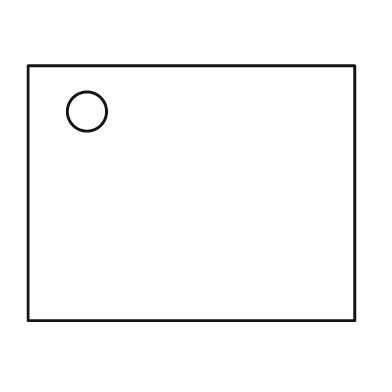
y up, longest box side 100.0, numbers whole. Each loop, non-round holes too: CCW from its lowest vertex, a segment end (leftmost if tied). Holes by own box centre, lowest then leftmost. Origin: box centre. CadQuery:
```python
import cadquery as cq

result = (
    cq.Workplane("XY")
    .moveTo(-50.0, -39.0)
    .lineTo(50.0, -39.0)
    .lineTo(50.0, 39.0)
    .lineTo(-50.0, 39.0)
    .close()
    .moveTo(-32.0, 25.0)
    .circle(6.0)
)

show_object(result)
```